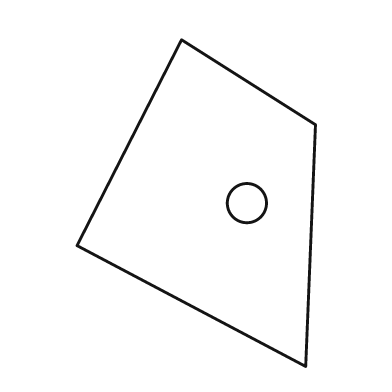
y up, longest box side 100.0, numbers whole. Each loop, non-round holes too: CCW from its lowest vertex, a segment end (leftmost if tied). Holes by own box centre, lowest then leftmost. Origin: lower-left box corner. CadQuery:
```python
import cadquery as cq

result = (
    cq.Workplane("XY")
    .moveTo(70.0, 0.0)
    .lineTo(73.0, 74.0)
    .lineTo(32.0, 100.0)
    .lineTo(0.0, 37.0)
    .close()
    .moveTo(52.0, 50.0)
    .circle(6.0)
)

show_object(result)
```